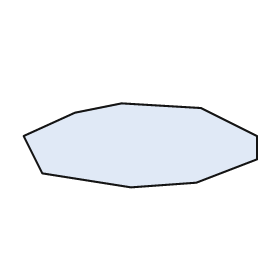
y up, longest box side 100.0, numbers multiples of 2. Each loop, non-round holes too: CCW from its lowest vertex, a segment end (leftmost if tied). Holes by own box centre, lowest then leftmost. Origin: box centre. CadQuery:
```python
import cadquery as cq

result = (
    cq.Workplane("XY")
    .moveTo(-4.0, -18.0)
    .lineTo(24.0, -16.0)
    .lineTo(50.0, -6.0)
    .lineTo(50.0, 4.0)
    .lineTo(26.0, 16.0)
    .lineTo(-8.0, 18.0)
    .lineTo(-28.0, 14.0)
    .lineTo(-50.0, 4.0)
    .lineTo(-42.0, -12.0)
    .close()
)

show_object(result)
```